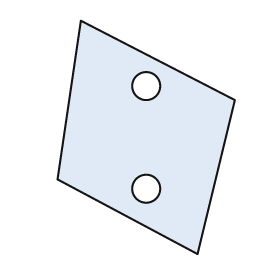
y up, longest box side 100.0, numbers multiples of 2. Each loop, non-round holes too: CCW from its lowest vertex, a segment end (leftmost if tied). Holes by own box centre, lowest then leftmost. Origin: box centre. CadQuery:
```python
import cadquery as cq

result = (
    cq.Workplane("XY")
    .moveTo(22.0, -50.0)
    .lineTo(38.0, 16.0)
    .lineTo(-28.0, 50.0)
    .lineTo(-38.0, -18.0)
    .close()
    .moveTo(0.0, -22.0)
    .circle(6.0)
    .moveTo(0.0, 22.0)
    .circle(6.0)
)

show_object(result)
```